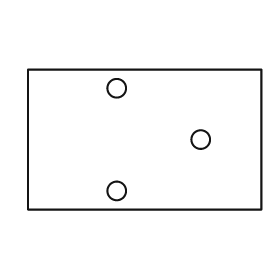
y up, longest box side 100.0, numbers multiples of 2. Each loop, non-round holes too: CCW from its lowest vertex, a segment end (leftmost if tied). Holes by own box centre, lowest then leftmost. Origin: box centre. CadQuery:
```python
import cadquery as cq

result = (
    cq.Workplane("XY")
    .moveTo(-50.0, -30.0)
    .lineTo(50.0, -30.0)
    .lineTo(50.0, 30.0)
    .lineTo(-50.0, 30.0)
    .close()
    .moveTo(-12.0, -22.0)
    .circle(4.0)
    .moveTo(24.0, 0.0)
    .circle(4.0)
    .moveTo(-12.0, 22.0)
    .circle(4.0)
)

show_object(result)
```